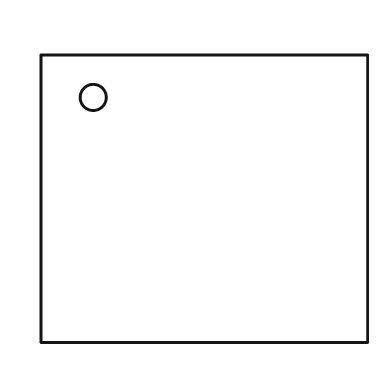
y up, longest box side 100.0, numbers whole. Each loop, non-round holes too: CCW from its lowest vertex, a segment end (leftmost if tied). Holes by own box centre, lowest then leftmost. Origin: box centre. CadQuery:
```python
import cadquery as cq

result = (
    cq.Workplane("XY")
    .moveTo(-50.0, -44.0)
    .lineTo(50.0, -44.0)
    .lineTo(50.0, 44.0)
    .lineTo(-50.0, 44.0)
    .close()
    .moveTo(-34.0, 31.0)
    .circle(4.0)
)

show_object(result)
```